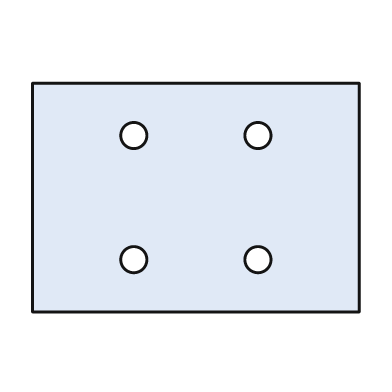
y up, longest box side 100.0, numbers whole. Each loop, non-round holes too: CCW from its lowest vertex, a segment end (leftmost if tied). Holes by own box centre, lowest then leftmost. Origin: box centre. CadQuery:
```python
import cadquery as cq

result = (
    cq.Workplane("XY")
    .moveTo(-50.0, -35.0)
    .lineTo(50.0, -35.0)
    .lineTo(50.0, 35.0)
    .lineTo(-50.0, 35.0)
    .close()
    .moveTo(-19.0, -19.0)
    .circle(4.0)
    .moveTo(19.0, -19.0)
    .circle(4.0)
    .moveTo(-19.0, 19.0)
    .circle(4.0)
    .moveTo(19.0, 19.0)
    .circle(4.0)
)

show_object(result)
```